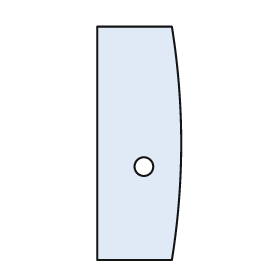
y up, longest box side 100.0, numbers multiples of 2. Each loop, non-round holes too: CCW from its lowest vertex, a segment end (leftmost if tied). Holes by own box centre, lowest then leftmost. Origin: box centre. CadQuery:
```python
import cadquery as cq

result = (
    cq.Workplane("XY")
    .moveTo(-18.0, -50.0)
    .lineTo(14.0, -50.0)
    .threePointArc((18.0, 0.0), (14.0, 50.0))
    .lineTo(-18.0, 50.0)
    .close()
    .moveTo(2.0, -10.0)
    .circle(4.0)
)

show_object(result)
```